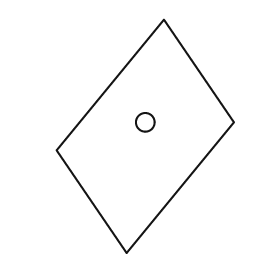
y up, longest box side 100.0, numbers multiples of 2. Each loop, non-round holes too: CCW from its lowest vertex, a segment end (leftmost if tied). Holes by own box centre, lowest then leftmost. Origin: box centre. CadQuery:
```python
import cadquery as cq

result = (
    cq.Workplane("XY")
    .moveTo(-8.0, -50.0)
    .lineTo(38.0, 6.0)
    .lineTo(8.0, 50.0)
    .lineTo(-38.0, -6.0)
    .close()
    .moveTo(0.0, 6.0)
    .circle(4.0)
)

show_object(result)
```